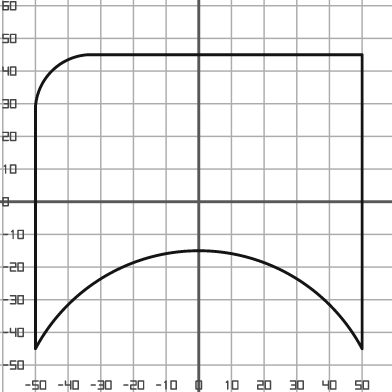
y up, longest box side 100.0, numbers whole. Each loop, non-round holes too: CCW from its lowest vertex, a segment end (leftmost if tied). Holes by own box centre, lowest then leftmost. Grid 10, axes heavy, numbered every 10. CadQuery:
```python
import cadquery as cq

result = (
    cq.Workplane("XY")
    .moveTo(-50.0, -45.0)
    .threePointArc((0.0, -15.0), (50.0, -45.0))
    .lineTo(50.0, 45.0)
    .lineTo(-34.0, 45.0)
    .threePointArc((-45.0, 40.0), (-50.0, 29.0))
    .close()
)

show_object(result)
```